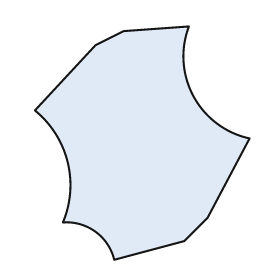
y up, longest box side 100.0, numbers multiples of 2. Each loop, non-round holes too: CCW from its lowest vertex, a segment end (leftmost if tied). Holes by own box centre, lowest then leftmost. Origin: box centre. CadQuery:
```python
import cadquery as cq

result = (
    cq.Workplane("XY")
    .moveTo(-12.0, -50.0)
    .lineTo(18.0, -42.0)
    .lineTo(28.0, -32.0)
    .lineTo(46.0, 2.0)
    .threePointArc((22.0, 20.0), (20.0, 50.0))
    .lineTo(-8.0, 48.0)
    .lineTo(-20.0, 42.0)
    .lineTo(-46.0, 14.0)
    .threePointArc((-32.0, -8.0), (-34.0, -34.0))
    .threePointArc((-20.0, -38.0), (-12.0, -50.0))
    .close()
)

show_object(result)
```